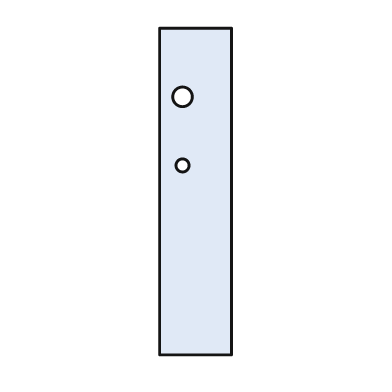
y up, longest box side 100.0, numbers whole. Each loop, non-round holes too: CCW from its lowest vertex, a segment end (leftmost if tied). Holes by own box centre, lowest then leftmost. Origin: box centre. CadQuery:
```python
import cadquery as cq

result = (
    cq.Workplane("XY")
    .moveTo(-11.0, -50.0)
    .lineTo(11.0, -50.0)
    .lineTo(11.0, 50.0)
    .lineTo(-11.0, 50.0)
    .close()
    .moveTo(-4.0, 8.0)
    .circle(2.0)
    .moveTo(-4.0, 29.0)
    .circle(3.0)
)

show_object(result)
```